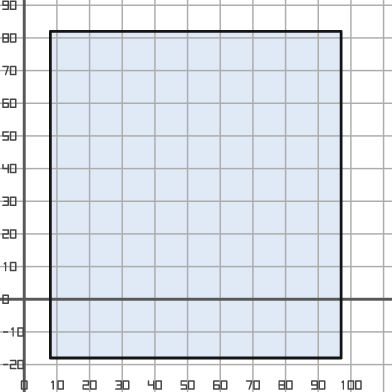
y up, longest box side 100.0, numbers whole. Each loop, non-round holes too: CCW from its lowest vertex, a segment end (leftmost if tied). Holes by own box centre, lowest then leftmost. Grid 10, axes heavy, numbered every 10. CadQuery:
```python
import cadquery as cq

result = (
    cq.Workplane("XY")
    .moveTo(8.0, -18.0)
    .lineTo(97.0, -18.0)
    .lineTo(97.0, 82.0)
    .lineTo(8.0, 82.0)
    .close()
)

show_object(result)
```